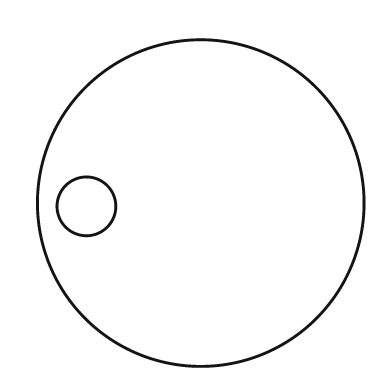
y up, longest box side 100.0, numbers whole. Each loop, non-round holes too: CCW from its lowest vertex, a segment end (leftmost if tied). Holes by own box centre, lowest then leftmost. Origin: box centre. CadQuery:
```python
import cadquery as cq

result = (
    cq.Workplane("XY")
    .moveTo(0.0, 0.0)
    .circle(50.0)
    .moveTo(-35.0, -1.0)
    .circle(9.0)
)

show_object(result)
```